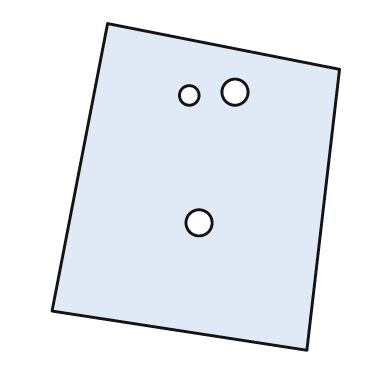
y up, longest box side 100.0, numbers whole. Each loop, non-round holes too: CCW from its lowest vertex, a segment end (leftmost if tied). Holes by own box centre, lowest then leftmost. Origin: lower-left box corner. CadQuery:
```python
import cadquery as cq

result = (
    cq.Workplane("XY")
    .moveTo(78.0, 0.0)
    .lineTo(88.0, 86.0)
    .lineTo(17.0, 100.0)
    .lineTo(0.0, 12.0)
    .close()
    .moveTo(45.0, 39.0)
    .circle(4.0)
    .moveTo(42.0, 78.0)
    .circle(3.0)
    .moveTo(56.0, 79.0)
    .circle(4.0)
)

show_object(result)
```